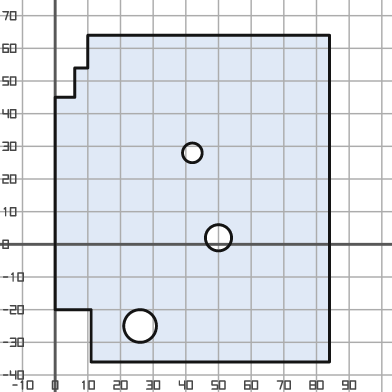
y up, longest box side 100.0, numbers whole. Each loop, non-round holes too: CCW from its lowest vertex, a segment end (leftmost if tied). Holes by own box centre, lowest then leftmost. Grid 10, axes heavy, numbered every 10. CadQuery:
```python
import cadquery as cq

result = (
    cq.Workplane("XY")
    .moveTo(11.0, -36.0)
    .lineTo(84.0, -36.0)
    .lineTo(84.0, 64.0)
    .lineTo(10.0, 64.0)
    .lineTo(10.0, 54.0)
    .lineTo(6.0, 54.0)
    .lineTo(6.0, 45.0)
    .lineTo(0.0, 45.0)
    .lineTo(0.0, -20.0)
    .lineTo(11.0, -20.0)
    .close()
    .moveTo(26.0, -25.0)
    .circle(5.0)
    .moveTo(50.0, 2.0)
    .circle(4.0)
    .moveTo(42.0, 28.0)
    .circle(3.0)
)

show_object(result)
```